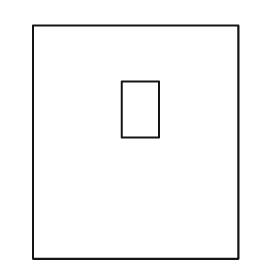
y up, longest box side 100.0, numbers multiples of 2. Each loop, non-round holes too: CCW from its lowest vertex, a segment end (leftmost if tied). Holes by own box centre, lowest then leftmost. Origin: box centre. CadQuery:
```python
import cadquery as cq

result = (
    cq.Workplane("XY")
    .moveTo(-44.0, -50.0)
    .lineTo(44.0, -50.0)
    .lineTo(44.0, 50.0)
    .lineTo(-44.0, 50.0)
    .close()
    .moveTo(-6.0, 2.0)
    .lineTo(10.0, 2.0)
    .lineTo(10.0, 26.0)
    .lineTo(-6.0, 26.0)
    .close()
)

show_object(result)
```